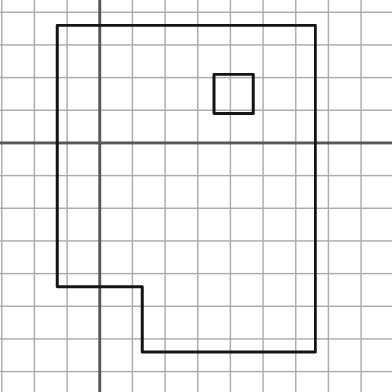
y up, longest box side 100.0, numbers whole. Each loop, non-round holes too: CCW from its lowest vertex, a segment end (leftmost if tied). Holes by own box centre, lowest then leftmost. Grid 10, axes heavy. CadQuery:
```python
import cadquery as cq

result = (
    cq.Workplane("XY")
    .moveTo(13.0, -64.0)
    .lineTo(66.0, -64.0)
    .lineTo(66.0, 36.0)
    .lineTo(-13.0, 36.0)
    .lineTo(-13.0, -44.0)
    .lineTo(13.0, -44.0)
    .close()
    .moveTo(35.0, 9.0)
    .lineTo(47.0, 9.0)
    .lineTo(47.0, 21.0)
    .lineTo(35.0, 21.0)
    .close()
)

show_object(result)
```